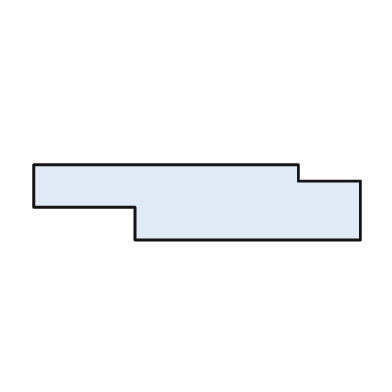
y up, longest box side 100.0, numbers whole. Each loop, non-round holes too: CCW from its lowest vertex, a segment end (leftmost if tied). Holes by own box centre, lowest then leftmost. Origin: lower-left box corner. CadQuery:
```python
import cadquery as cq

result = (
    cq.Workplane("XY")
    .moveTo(31.0, 0.0)
    .lineTo(100.0, 0.0)
    .lineTo(100.0, 18.0)
    .lineTo(81.0, 18.0)
    .lineTo(81.0, 23.0)
    .lineTo(0.0, 23.0)
    .lineTo(0.0, 10.0)
    .lineTo(31.0, 10.0)
    .close()
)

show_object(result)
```